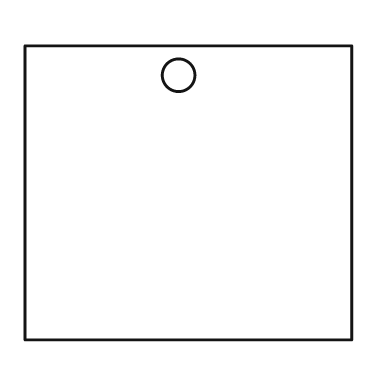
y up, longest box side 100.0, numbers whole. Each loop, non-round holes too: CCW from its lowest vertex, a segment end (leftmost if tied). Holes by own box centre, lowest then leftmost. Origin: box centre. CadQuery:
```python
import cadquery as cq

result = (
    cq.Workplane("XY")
    .moveTo(-50.0, -45.0)
    .lineTo(50.0, -45.0)
    .lineTo(50.0, 45.0)
    .lineTo(-50.0, 45.0)
    .close()
    .moveTo(-3.0, 36.0)
    .circle(5.0)
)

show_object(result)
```